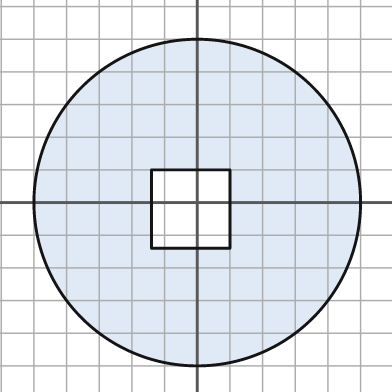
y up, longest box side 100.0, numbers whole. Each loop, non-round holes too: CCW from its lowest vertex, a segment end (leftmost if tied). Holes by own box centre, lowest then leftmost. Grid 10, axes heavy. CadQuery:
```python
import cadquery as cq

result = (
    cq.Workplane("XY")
    .moveTo(0.0, 0.0)
    .circle(50.0)
    .moveTo(-14.0, -14.0)
    .lineTo(10.0, -14.0)
    .lineTo(10.0, 10.0)
    .lineTo(-14.0, 10.0)
    .close()
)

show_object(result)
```